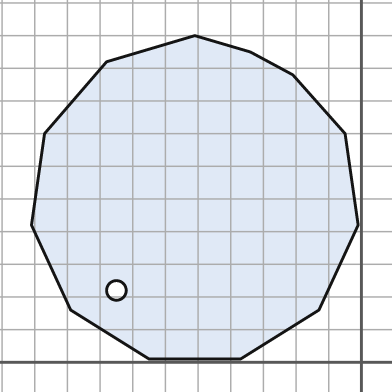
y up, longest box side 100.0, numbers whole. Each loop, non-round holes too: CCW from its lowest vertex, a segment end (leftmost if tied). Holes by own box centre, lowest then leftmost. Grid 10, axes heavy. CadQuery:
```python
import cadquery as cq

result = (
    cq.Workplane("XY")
    .moveTo(-65.0, 1.0)
    .lineTo(-37.0, 1.0)
    .lineTo(-13.0, 16.0)
    .lineTo(-1.0, 42.0)
    .lineTo(-5.0, 70.0)
    .lineTo(-21.0, 88.0)
    .lineTo(-34.0, 95.0)
    .lineTo(-51.0, 100.0)
    .lineTo(-78.0, 92.0)
    .lineTo(-97.0, 70.0)
    .lineTo(-101.0, 42.0)
    .lineTo(-89.0, 16.0)
    .close()
    .moveTo(-75.0, 22.0)
    .circle(3.0)
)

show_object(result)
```